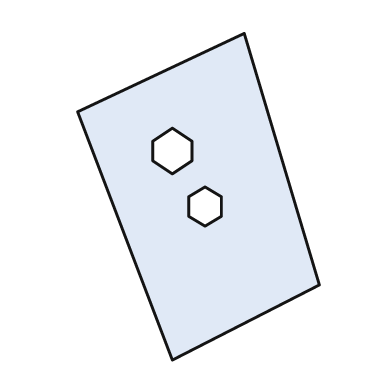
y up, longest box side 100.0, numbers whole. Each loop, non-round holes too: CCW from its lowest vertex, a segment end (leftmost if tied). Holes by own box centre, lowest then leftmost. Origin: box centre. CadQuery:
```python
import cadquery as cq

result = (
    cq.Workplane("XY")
    .moveTo(-8.0, -50.0)
    .lineTo(37.0, -27.0)
    .lineTo(14.0, 50.0)
    .lineTo(-37.0, 26.0)
    .close()
    .moveTo(2.0, -9.0)
    .lineTo(7.0, -6.0)
    .lineTo(7.0, 0.0)
    .lineTo(2.0, 3.0)
    .lineTo(-3.0, 0.0)
    .lineTo(-3.0, -6.0)
    .close()
    .moveTo(-8.0, 7.0)
    .lineTo(-2.0, 11.0)
    .lineTo(-2.0, 17.0)
    .lineTo(-8.0, 21.0)
    .lineTo(-14.0, 17.0)
    .lineTo(-14.0, 11.0)
    .close()
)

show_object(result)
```